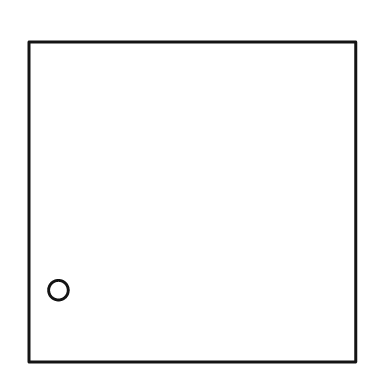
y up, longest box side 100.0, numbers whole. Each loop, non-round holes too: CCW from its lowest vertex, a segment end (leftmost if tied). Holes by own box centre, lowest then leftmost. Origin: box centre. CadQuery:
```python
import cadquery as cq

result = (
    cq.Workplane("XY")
    .moveTo(-50.0, -49.0)
    .lineTo(50.0, -49.0)
    .lineTo(50.0, 49.0)
    .lineTo(-50.0, 49.0)
    .close()
    .moveTo(-41.0, -27.0)
    .circle(3.0)
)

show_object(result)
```